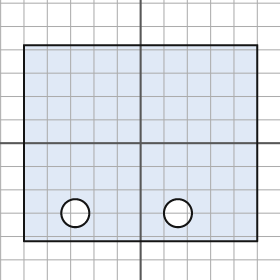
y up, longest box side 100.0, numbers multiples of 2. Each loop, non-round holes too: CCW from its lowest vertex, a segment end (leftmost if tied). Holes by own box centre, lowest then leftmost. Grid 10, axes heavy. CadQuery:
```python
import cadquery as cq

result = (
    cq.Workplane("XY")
    .moveTo(-50.0, -42.0)
    .lineTo(50.0, -42.0)
    .lineTo(50.0, 42.0)
    .lineTo(-50.0, 42.0)
    .close()
    .moveTo(-28.0, -30.0)
    .circle(6.0)
    .moveTo(16.0, -30.0)
    .circle(6.0)
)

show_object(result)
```